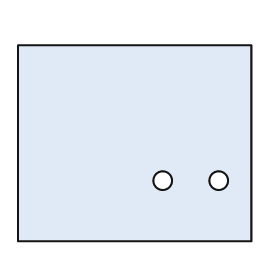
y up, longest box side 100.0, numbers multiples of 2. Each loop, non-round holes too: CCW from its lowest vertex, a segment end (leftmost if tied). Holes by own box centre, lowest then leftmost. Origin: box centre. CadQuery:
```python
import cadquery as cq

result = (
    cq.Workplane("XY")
    .moveTo(-50.0, -42.0)
    .lineTo(50.0, -42.0)
    .lineTo(50.0, 42.0)
    .lineTo(-50.0, 42.0)
    .close()
    .moveTo(12.0, -16.0)
    .circle(4.0)
    .moveTo(36.0, -16.0)
    .circle(4.0)
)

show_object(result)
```